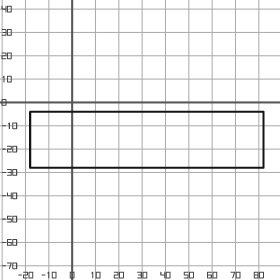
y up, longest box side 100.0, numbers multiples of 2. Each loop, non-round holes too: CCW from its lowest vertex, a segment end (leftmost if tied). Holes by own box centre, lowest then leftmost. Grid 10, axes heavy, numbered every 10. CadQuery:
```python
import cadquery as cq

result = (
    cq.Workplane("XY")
    .moveTo(-18.0, -28.0)
    .lineTo(82.0, -28.0)
    .lineTo(82.0, -4.0)
    .lineTo(-18.0, -4.0)
    .close()
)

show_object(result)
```